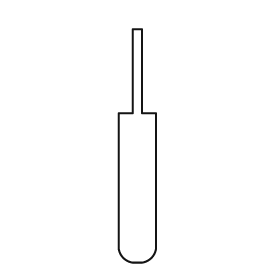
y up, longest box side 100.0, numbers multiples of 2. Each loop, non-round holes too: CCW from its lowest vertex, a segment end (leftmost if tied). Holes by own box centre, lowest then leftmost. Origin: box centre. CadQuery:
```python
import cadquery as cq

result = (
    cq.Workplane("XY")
    .moveTo(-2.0, -50.0)
    .lineTo(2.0, -50.0)
    .threePointArc((6.0, -48.0), (8.0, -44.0))
    .lineTo(8.0, 14.0)
    .lineTo(2.0, 14.0)
    .lineTo(2.0, 50.0)
    .lineTo(-2.0, 50.0)
    .lineTo(-2.0, 14.0)
    .lineTo(-8.0, 14.0)
    .lineTo(-8.0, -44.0)
    .threePointArc((-6.0, -48.0), (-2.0, -50.0))
    .close()
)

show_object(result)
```